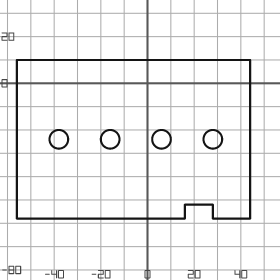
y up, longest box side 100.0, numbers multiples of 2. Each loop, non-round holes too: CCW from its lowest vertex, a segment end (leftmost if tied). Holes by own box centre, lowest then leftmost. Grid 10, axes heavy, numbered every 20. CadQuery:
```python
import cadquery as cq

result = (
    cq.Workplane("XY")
    .moveTo(-56.0, -58.0)
    .lineTo(16.0, -58.0)
    .lineTo(16.0, -52.0)
    .lineTo(28.0, -52.0)
    .lineTo(28.0, -58.0)
    .lineTo(44.0, -58.0)
    .lineTo(44.0, 10.0)
    .lineTo(-56.0, 10.0)
    .close()
    .moveTo(-38.0, -24.0)
    .circle(4.0)
    .moveTo(-16.0, -24.0)
    .circle(4.0)
    .moveTo(6.0, -24.0)
    .circle(4.0)
    .moveTo(28.0, -24.0)
    .circle(4.0)
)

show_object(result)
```